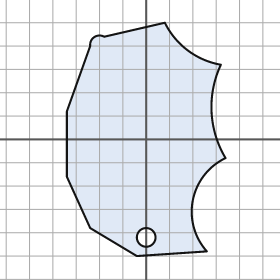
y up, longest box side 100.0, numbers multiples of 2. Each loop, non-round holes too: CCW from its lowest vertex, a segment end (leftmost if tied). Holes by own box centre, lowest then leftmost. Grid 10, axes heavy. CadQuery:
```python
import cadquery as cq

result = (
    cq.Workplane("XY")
    .moveTo(-4.0, -50.0)
    .lineTo(26.0, -48.0)
    .threePointArc((20.0, -26.0), (34.0, -8.0))
    .threePointArc((28.0, 12.0), (32.0, 32.0))
    .threePointArc((18.0, 38.0), (8.0, 50.0))
    .lineTo(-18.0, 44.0)
    .threePointArc((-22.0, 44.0), (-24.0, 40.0))
    .lineTo(-34.0, 12.0)
    .lineTo(-34.0, -16.0)
    .lineTo(-24.0, -38.0)
    .close()
    .moveTo(0.0, -42.0)
    .circle(4.0)
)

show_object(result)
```